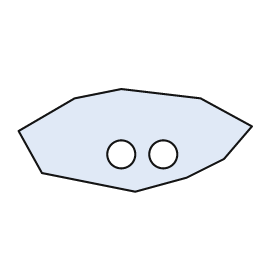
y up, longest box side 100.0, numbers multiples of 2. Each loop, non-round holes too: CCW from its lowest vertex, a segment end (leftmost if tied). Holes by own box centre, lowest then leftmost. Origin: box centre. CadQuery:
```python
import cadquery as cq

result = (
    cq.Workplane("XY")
    .moveTo(0.0, -22.0)
    .lineTo(22.0, -16.0)
    .lineTo(38.0, -8.0)
    .lineTo(50.0, 6.0)
    .lineTo(28.0, 18.0)
    .lineTo(-6.0, 22.0)
    .lineTo(-26.0, 18.0)
    .lineTo(-50.0, 4.0)
    .lineTo(-40.0, -14.0)
    .close()
    .moveTo(-6.0, -6.0)
    .circle(6.0)
    .moveTo(12.0, -6.0)
    .circle(6.0)
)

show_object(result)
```